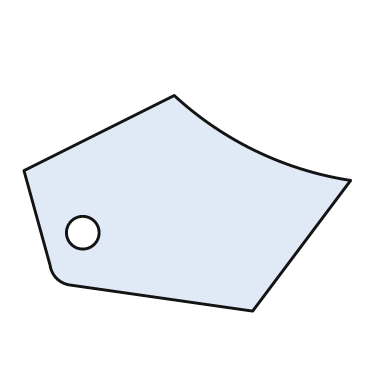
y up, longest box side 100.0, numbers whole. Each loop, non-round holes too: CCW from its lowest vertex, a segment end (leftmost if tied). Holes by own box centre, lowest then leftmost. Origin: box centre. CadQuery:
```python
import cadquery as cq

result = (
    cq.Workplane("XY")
    .moveTo(20.0, -33.0)
    .lineTo(50.0, 7.0)
    .threePointArc((21.0, 16.0), (-4.0, 33.0))
    .lineTo(-50.0, 10.0)
    .lineTo(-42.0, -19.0)
    .threePointArc((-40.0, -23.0), (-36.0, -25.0))
    .close()
    .moveTo(-32.0, -9.0)
    .circle(5.0)
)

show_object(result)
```